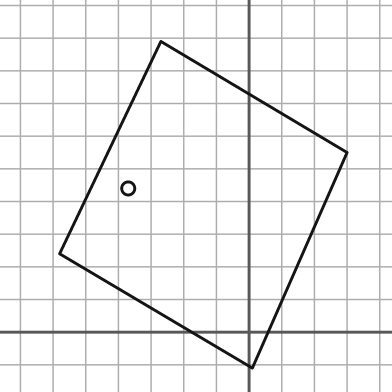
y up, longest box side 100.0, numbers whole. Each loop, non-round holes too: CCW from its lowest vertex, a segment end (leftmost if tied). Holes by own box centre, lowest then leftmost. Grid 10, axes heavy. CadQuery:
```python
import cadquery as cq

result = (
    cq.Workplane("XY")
    .moveTo(1.0, -11.0)
    .lineTo(30.0, 55.0)
    .lineTo(-27.0, 89.0)
    .lineTo(-58.0, 24.0)
    .close()
    .moveTo(-37.0, 44.0)
    .circle(2.0)
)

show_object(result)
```